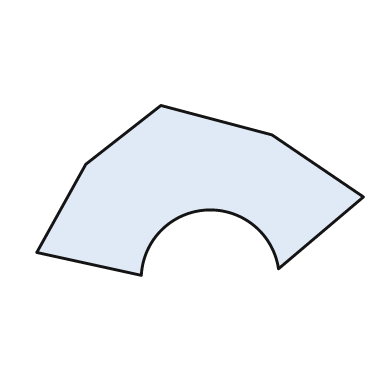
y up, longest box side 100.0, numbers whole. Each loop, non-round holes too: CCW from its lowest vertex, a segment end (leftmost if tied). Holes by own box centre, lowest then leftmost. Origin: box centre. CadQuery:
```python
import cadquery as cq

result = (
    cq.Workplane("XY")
    .moveTo(-18.0, -26.0)
    .threePointArc((2.0, -6.0), (24.0, -24.0))
    .lineTo(50.0, -2.0)
    .lineTo(22.0, 17.0)
    .lineTo(-12.0, 26.0)
    .lineTo(-35.0, 8.0)
    .lineTo(-50.0, -19.0)
    .close()
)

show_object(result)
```